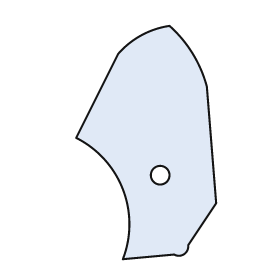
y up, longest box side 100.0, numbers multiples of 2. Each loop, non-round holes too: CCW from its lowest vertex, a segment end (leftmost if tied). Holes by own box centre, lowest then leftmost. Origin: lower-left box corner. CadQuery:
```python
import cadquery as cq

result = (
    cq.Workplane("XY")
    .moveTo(20.0, 0.0)
    .lineTo(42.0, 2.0)
    .threePointArc((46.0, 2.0), (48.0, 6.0))
    .lineTo(60.0, 24.0)
    .lineTo(56.0, 74.0)
    .threePointArc((50.0, 88.0), (40.0, 100.0))
    .threePointArc((28.0, 96.0), (18.0, 88.0))
    .lineTo(0.0, 52.0)
    .threePointArc((20.0, 30.0), (20.0, 0.0))
    .close()
    .moveTo(36.0, 36.0)
    .circle(4.0)
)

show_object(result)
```